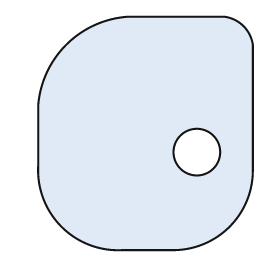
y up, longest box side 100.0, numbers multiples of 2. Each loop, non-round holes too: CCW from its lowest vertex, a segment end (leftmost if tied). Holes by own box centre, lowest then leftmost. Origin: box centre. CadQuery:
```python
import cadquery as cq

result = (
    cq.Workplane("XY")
    .moveTo(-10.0, -50.0)
    .lineTo(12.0, -50.0)
    .threePointArc((36.0, -40.0), (46.0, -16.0))
    .lineTo(46.0, 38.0)
    .threePointArc((42.0, 46.0), (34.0, 50.0))
    .lineTo(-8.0, 50.0)
    .threePointArc((-34.0, 38.0), (-46.0, 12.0))
    .lineTo(-46.0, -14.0)
    .threePointArc((-36.0, -40.0), (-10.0, -50.0))
    .close()
    .moveTo(22.0, -8.0)
    .circle(10.0)
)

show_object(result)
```